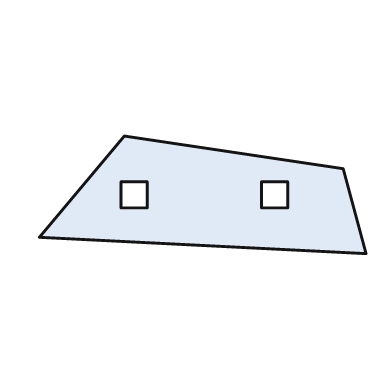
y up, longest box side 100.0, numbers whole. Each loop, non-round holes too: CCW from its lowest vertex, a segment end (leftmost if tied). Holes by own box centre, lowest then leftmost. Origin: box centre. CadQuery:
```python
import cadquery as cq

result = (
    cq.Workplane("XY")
    .moveTo(50.0, -18.0)
    .lineTo(43.0, 8.0)
    .lineTo(-24.0, 18.0)
    .lineTo(-50.0, -13.0)
    .close()
    .moveTo(-25.0, -4.0)
    .lineTo(-17.0, -4.0)
    .lineTo(-17.0, 4.0)
    .lineTo(-25.0, 4.0)
    .close()
    .moveTo(18.0, -4.0)
    .lineTo(26.0, -4.0)
    .lineTo(26.0, 4.0)
    .lineTo(18.0, 4.0)
    .close()
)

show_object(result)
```